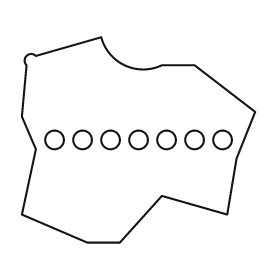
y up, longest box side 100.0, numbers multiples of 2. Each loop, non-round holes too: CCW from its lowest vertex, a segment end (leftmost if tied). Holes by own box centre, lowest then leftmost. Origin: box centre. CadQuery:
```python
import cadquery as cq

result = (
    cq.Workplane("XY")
    .moveTo(-22.0, -44.0)
    .lineTo(-8.0, -44.0)
    .lineTo(10.0, -24.0)
    .lineTo(38.0, -32.0)
    .lineTo(42.0, -8.0)
    .lineTo(50.0, 12.0)
    .lineTo(24.0, 32.0)
    .lineTo(10.0, 32.0)
    .threePointArc((-6.0, 32.0), (-16.0, 44.0))
    .lineTo(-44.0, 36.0)
    .threePointArc((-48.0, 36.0), (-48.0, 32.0))
    .lineTo(-50.0, 10.0)
    .lineTo(-44.0, -4.0)
    .lineTo(-50.0, -32.0)
    .close()
    .moveTo(-36.0, 0.0)
    .circle(4.0)
    .moveTo(-24.0, 0.0)
    .circle(4.0)
    .moveTo(-12.0, 0.0)
    .circle(4.0)
    .moveTo(0.0, 0.0)
    .circle(4.0)
    .moveTo(12.0, 0.0)
    .circle(4.0)
    .moveTo(24.0, 0.0)
    .circle(4.0)
    .moveTo(36.0, 0.0)
    .circle(4.0)
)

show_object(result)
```